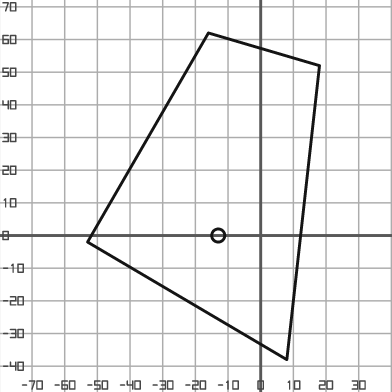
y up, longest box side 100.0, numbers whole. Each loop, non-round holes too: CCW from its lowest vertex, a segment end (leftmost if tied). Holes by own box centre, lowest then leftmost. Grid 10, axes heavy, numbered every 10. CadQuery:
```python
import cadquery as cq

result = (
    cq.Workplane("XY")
    .moveTo(8.0, -38.0)
    .lineTo(18.0, 52.0)
    .lineTo(-16.0, 62.0)
    .lineTo(-53.0, -2.0)
    .close()
    .moveTo(-13.0, 0.0)
    .circle(2.0)
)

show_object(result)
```